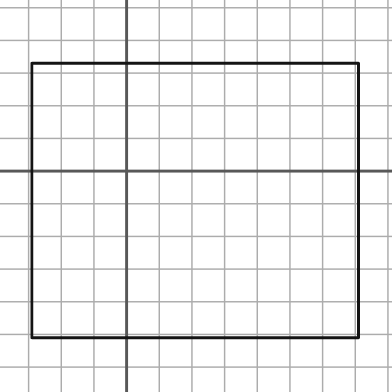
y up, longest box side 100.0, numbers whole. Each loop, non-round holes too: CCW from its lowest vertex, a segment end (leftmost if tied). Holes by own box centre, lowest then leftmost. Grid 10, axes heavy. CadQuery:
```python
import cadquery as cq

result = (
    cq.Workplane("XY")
    .moveTo(-29.0, -51.0)
    .lineTo(71.0, -51.0)
    .lineTo(71.0, 33.0)
    .lineTo(-29.0, 33.0)
    .close()
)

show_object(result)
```